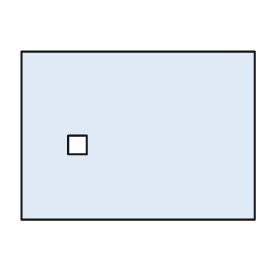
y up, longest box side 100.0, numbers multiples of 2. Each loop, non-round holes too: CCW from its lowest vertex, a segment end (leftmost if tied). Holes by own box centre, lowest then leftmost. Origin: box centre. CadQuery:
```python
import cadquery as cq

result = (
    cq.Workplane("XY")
    .moveTo(-50.0, -36.0)
    .lineTo(50.0, -36.0)
    .lineTo(50.0, 36.0)
    .lineTo(-50.0, 36.0)
    .close()
    .moveTo(-30.0, -8.0)
    .lineTo(-22.0, -8.0)
    .lineTo(-22.0, 0.0)
    .lineTo(-30.0, 0.0)
    .close()
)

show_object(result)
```